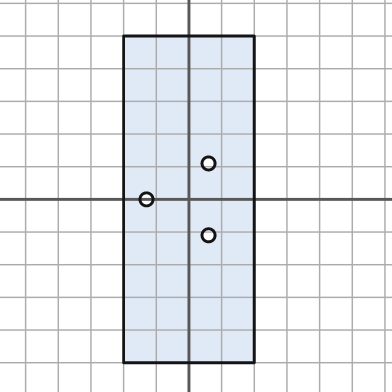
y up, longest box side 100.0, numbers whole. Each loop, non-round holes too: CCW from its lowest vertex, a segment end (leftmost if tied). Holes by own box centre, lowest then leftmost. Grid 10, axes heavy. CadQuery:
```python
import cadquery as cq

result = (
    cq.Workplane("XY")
    .moveTo(-20.0, -50.0)
    .lineTo(20.0, -50.0)
    .lineTo(20.0, 50.0)
    .lineTo(-20.0, 50.0)
    .close()
    .moveTo(6.0, -11.0)
    .circle(2.0)
    .moveTo(-13.0, 0.0)
    .circle(2.0)
    .moveTo(6.0, 11.0)
    .circle(2.0)
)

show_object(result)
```